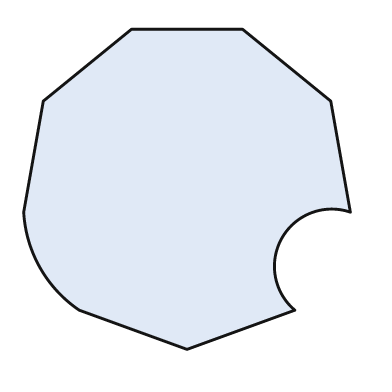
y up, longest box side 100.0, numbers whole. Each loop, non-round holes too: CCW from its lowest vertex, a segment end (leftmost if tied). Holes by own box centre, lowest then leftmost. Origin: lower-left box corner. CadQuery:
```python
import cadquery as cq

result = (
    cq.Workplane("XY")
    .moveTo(50.0, 0.0)
    .lineTo(83.0, 12.0)
    .threePointArc((79.0, 34.0), (100.0, 42.0))
    .lineTo(94.0, 76.0)
    .lineTo(67.0, 98.0)
    .lineTo(33.0, 98.0)
    .lineTo(6.0, 76.0)
    .lineTo(0.0, 42.0)
    .threePointArc((5.0, 25.0), (17.0, 12.0))
    .close()
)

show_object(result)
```